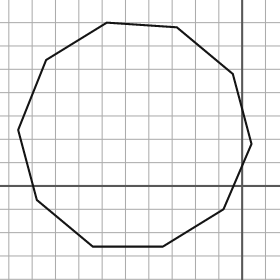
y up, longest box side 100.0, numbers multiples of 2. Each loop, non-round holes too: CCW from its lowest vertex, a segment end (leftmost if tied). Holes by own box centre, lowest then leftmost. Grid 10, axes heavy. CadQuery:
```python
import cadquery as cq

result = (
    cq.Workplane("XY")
    .moveTo(-64.0, -26.0)
    .lineTo(-34.0, -26.0)
    .lineTo(-8.0, -10.0)
    .lineTo(4.0, 18.0)
    .lineTo(-4.0, 48.0)
    .lineTo(-28.0, 68.0)
    .lineTo(-58.0, 70.0)
    .lineTo(-84.0, 54.0)
    .lineTo(-96.0, 24.0)
    .lineTo(-88.0, -6.0)
    .close()
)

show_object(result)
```